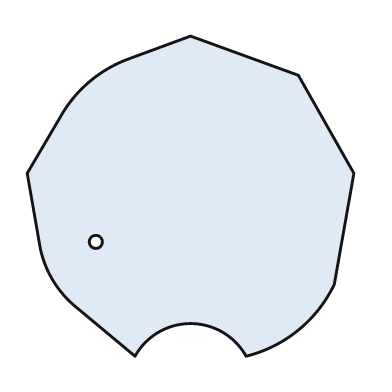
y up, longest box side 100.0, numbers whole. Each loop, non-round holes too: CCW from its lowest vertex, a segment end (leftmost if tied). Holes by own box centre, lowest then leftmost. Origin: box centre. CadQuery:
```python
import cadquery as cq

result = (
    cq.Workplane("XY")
    .moveTo(-17.0, -49.0)
    .threePointArc((0.0, -39.0), (17.0, -49.0))
    .threePointArc((33.0, -41.0), (44.0, -27.0))
    .lineTo(50.0, 7.0)
    .lineTo(33.0, 37.0)
    .lineTo(0.0, 49.0)
    .lineTo(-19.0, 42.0)
    .threePointArc((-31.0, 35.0), (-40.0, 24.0))
    .lineTo(-50.0, 7.0)
    .lineTo(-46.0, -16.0)
    .threePointArc((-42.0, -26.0), (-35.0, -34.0))
    .close()
    .moveTo(-29.0, -14.0)
    .circle(2.0)
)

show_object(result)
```